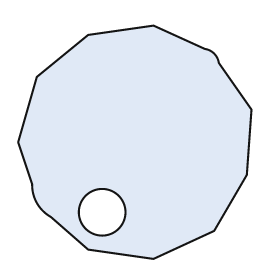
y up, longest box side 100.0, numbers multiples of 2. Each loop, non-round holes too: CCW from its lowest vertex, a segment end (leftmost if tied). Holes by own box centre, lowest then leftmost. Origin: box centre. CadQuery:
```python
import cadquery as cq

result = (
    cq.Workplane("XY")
    .moveTo(8.0, -50.0)
    .lineTo(34.0, -38.0)
    .lineTo(48.0, -14.0)
    .lineTo(50.0, 14.0)
    .lineTo(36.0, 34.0)
    .threePointArc((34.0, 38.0), (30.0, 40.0))
    .lineTo(8.0, 50.0)
    .lineTo(-20.0, 46.0)
    .lineTo(-42.0, 28.0)
    .lineTo(-50.0, 0.0)
    .lineTo(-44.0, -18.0)
    .threePointArc((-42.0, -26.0), (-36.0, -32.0))
    .lineTo(-20.0, -46.0)
    .close()
    .moveTo(-14.0, -30.0)
    .circle(10.0)
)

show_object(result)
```